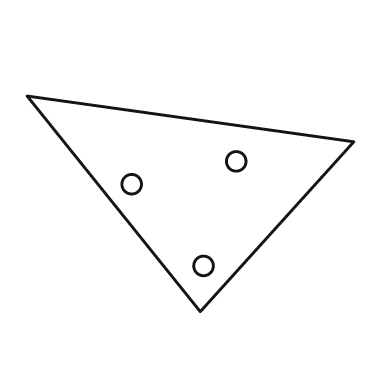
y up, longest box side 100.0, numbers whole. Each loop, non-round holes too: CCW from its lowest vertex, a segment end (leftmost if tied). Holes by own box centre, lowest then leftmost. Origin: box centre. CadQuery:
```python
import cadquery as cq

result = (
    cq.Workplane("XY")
    .moveTo(3.0, -33.0)
    .lineTo(50.0, 19.0)
    .lineTo(-50.0, 33.0)
    .close()
    .moveTo(4.0, -19.0)
    .circle(3.0)
    .moveTo(-18.0, 6.0)
    .circle(3.0)
    .moveTo(14.0, 13.0)
    .circle(3.0)
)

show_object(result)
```